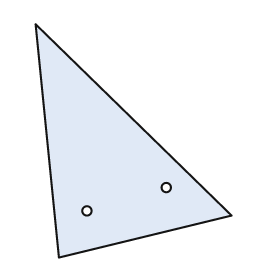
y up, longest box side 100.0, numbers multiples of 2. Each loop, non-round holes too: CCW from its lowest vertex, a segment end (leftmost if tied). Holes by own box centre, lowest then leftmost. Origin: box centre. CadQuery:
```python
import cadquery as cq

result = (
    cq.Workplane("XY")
    .moveTo(-32.0, -50.0)
    .lineTo(42.0, -32.0)
    .lineTo(-42.0, 50.0)
    .close()
    .moveTo(-20.0, -30.0)
    .circle(2.0)
    .moveTo(14.0, -20.0)
    .circle(2.0)
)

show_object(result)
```